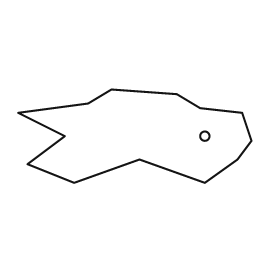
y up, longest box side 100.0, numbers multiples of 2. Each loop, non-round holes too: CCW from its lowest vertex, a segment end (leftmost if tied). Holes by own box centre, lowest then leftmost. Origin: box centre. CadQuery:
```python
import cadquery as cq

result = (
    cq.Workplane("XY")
    .moveTo(-26.0, -20.0)
    .lineTo(2.0, -10.0)
    .lineTo(30.0, -20.0)
    .lineTo(44.0, -10.0)
    .lineTo(50.0, -2.0)
    .lineTo(46.0, 10.0)
    .lineTo(28.0, 12.0)
    .lineTo(18.0, 18.0)
    .lineTo(-10.0, 20.0)
    .lineTo(-20.0, 14.0)
    .lineTo(-50.0, 10.0)
    .lineTo(-30.0, 0.0)
    .lineTo(-46.0, -12.0)
    .close()
    .moveTo(30.0, 0.0)
    .circle(2.0)
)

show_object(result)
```